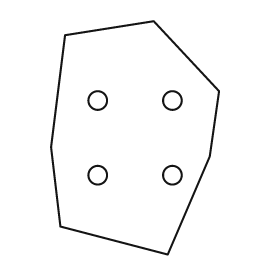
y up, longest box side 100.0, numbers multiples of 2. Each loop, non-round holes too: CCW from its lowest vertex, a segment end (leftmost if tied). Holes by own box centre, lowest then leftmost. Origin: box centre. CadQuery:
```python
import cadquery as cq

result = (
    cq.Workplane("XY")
    .moveTo(14.0, -50.0)
    .lineTo(32.0, -8.0)
    .lineTo(36.0, 20.0)
    .lineTo(8.0, 50.0)
    .lineTo(-30.0, 44.0)
    .lineTo(-36.0, -4.0)
    .lineTo(-32.0, -38.0)
    .close()
    .moveTo(-16.0, -16.0)
    .circle(4.0)
    .moveTo(16.0, -16.0)
    .circle(4.0)
    .moveTo(-16.0, 16.0)
    .circle(4.0)
    .moveTo(16.0, 16.0)
    .circle(4.0)
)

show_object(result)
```